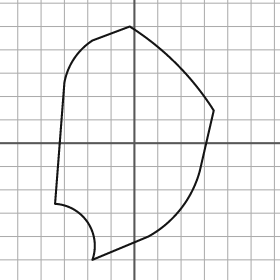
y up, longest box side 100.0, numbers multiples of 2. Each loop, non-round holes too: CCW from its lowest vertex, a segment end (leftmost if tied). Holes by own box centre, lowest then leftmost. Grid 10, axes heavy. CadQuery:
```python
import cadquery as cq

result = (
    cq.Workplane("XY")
    .moveTo(-18.0, -50.0)
    .lineTo(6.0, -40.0)
    .threePointArc((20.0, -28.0), (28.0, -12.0))
    .lineTo(34.0, 14.0)
    .threePointArc((18.0, 34.0), (-2.0, 50.0))
    .lineTo(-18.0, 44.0)
    .threePointArc((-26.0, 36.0), (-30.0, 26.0))
    .lineTo(-34.0, -26.0)
    .threePointArc((-20.0, -34.0), (-18.0, -50.0))
    .close()
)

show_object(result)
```